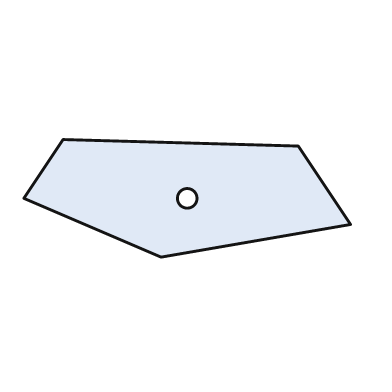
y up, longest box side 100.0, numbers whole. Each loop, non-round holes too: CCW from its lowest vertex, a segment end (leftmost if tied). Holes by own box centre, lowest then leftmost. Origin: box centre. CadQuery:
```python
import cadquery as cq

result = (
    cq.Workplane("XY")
    .moveTo(-8.0, -18.0)
    .lineTo(50.0, -8.0)
    .lineTo(34.0, 16.0)
    .lineTo(-38.0, 18.0)
    .lineTo(-50.0, 0.0)
    .close()
    .moveTo(0.0, 0.0)
    .circle(3.0)
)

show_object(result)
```